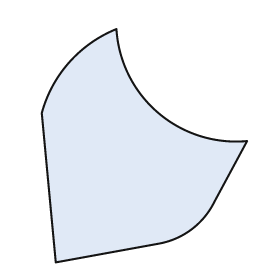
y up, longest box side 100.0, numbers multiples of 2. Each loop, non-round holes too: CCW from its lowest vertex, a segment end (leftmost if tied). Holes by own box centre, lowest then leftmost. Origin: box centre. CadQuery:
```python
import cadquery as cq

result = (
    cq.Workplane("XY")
    .moveTo(-38.0, -50.0)
    .lineTo(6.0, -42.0)
    .threePointArc((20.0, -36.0), (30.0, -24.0))
    .lineTo(44.0, 2.0)
    .threePointArc((6.0, 14.0), (-12.0, 50.0))
    .threePointArc((-32.0, 36.0), (-44.0, 14.0))
    .close()
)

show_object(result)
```